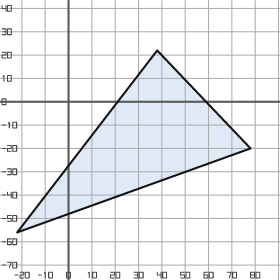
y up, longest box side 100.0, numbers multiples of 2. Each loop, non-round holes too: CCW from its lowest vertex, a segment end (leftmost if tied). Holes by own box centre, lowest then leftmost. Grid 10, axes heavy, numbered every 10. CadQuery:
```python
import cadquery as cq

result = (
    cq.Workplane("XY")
    .moveTo(-22.0, -56.0)
    .lineTo(78.0, -20.0)
    .lineTo(38.0, 22.0)
    .close()
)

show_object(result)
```